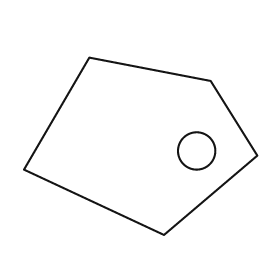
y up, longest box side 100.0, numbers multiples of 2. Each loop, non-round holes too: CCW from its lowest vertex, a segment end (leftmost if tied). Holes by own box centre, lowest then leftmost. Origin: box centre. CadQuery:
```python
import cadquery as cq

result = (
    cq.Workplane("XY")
    .moveTo(10.0, -38.0)
    .lineTo(50.0, -4.0)
    .lineTo(30.0, 28.0)
    .lineTo(-22.0, 38.0)
    .lineTo(-50.0, -10.0)
    .close()
    .moveTo(24.0, -2.0)
    .circle(8.0)
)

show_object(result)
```